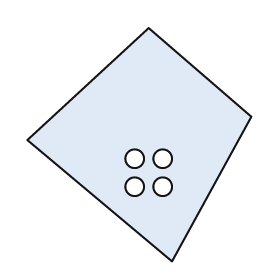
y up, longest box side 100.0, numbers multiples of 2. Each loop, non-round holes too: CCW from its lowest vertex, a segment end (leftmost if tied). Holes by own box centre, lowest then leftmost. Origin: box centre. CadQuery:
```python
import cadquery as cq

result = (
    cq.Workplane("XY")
    .moveTo(14.0, -50.0)
    .lineTo(48.0, 12.0)
    .lineTo(4.0, 50.0)
    .lineTo(-48.0, 2.0)
    .close()
    .moveTo(-2.0, -18.0)
    .circle(4.0)
    .moveTo(10.0, -18.0)
    .circle(4.0)
    .moveTo(-2.0, -6.0)
    .circle(4.0)
    .moveTo(10.0, -6.0)
    .circle(4.0)
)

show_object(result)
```